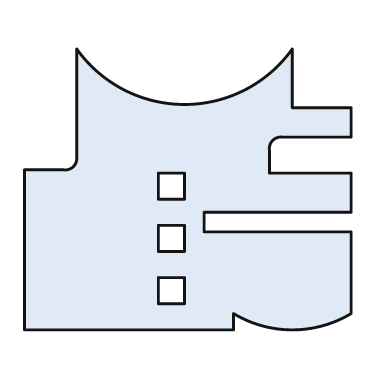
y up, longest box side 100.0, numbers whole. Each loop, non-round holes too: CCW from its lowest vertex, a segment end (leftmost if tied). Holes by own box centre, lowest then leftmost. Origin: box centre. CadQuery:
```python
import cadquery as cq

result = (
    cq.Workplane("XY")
    .moveTo(-50.0, -43.0)
    .lineTo(14.0, -43.0)
    .lineTo(14.0, -38.0)
    .threePointArc((32.0, -43.0), (50.0, -38.0))
    .lineTo(50.0, -13.0)
    .lineTo(5.0, -13.0)
    .lineTo(5.0, -7.0)
    .lineTo(50.0, -7.0)
    .lineTo(50.0, 5.0)
    .lineTo(25.0, 5.0)
    .lineTo(25.0, 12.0)
    .threePointArc((26.0, 15.0), (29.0, 16.0))
    .lineTo(50.0, 16.0)
    .lineTo(50.0, 25.0)
    .lineTo(32.0, 25.0)
    .lineTo(32.0, 43.0)
    .threePointArc((-1.0, 26.0), (-34.0, 43.0))
    .lineTo(-34.0, 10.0)
    .threePointArc((-35.0, 7.0), (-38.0, 6.0))
    .lineTo(-50.0, 6.0)
    .close()
    .moveTo(-9.0, -35.0)
    .lineTo(-1.0, -35.0)
    .lineTo(-1.0, -27.0)
    .lineTo(-9.0, -27.0)
    .close()
    .moveTo(-9.0, -19.0)
    .lineTo(-1.0, -19.0)
    .lineTo(-1.0, -11.0)
    .lineTo(-9.0, -11.0)
    .close()
    .moveTo(-9.0, -3.0)
    .lineTo(-1.0, -3.0)
    .lineTo(-1.0, 5.0)
    .lineTo(-9.0, 5.0)
    .close()
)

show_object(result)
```